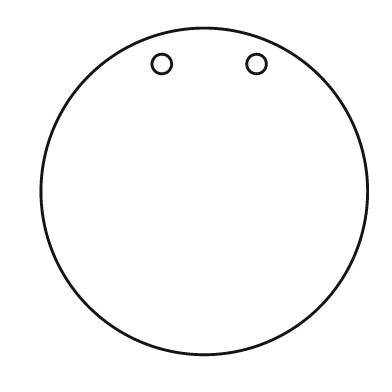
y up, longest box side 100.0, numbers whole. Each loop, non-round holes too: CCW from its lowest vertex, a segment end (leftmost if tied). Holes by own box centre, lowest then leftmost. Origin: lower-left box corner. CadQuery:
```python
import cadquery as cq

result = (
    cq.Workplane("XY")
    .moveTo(50.0, 50.0)
    .circle(50.0)
    .moveTo(37.0, 89.0)
    .circle(3.0)
    .moveTo(66.0, 89.0)
    .circle(3.0)
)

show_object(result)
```